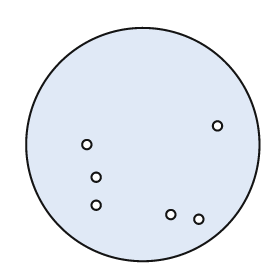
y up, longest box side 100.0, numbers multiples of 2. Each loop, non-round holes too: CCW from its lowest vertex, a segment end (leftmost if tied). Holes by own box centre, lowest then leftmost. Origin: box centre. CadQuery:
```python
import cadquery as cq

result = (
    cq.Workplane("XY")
    .moveTo(0.0, 0.0)
    .circle(50.0)
    .moveTo(24.0, -32.0)
    .circle(2.0)
    .moveTo(12.0, -30.0)
    .circle(2.0)
    .moveTo(-20.0, -26.0)
    .circle(2.0)
    .moveTo(-20.0, -14.0)
    .circle(2.0)
    .moveTo(-24.0, 0.0)
    .circle(2.0)
    .moveTo(32.0, 8.0)
    .circle(2.0)
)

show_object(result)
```